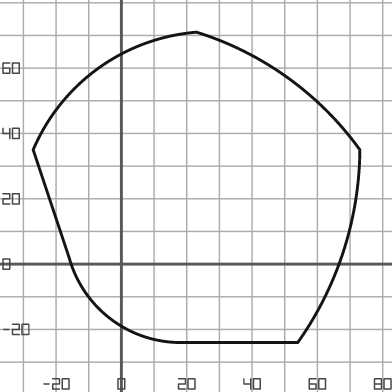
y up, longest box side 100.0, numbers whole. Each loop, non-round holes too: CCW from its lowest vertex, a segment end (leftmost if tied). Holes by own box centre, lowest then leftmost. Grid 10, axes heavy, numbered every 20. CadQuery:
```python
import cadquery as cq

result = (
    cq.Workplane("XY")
    .moveTo(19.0, -24.0)
    .lineTo(54.0, -24.0)
    .threePointArc((68.0, 4.0), (73.0, 35.0))
    .threePointArc((51.0, 57.0), (23.0, 71.0))
    .threePointArc((-7.0, 60.0), (-27.0, 35.0))
    .lineTo(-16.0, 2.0)
    .threePointArc((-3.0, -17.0), (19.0, -24.0))
    .close()
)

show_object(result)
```